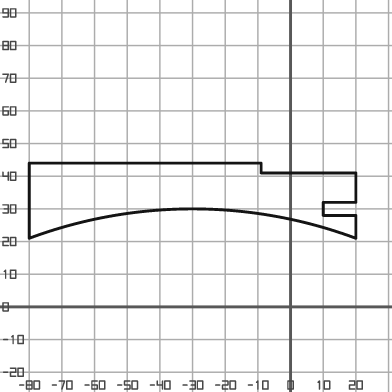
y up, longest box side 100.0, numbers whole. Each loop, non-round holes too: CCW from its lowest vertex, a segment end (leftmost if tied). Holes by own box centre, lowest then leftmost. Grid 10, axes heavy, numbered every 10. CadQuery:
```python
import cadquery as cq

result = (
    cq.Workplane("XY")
    .moveTo(-80.0, 21.0)
    .threePointArc((-30.0, 30.0), (20.0, 21.0))
    .lineTo(20.0, 28.0)
    .lineTo(10.0, 28.0)
    .lineTo(10.0, 32.0)
    .lineTo(20.0, 32.0)
    .lineTo(20.0, 41.0)
    .lineTo(-9.0, 41.0)
    .lineTo(-9.0, 44.0)
    .lineTo(-80.0, 44.0)
    .close()
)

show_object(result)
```